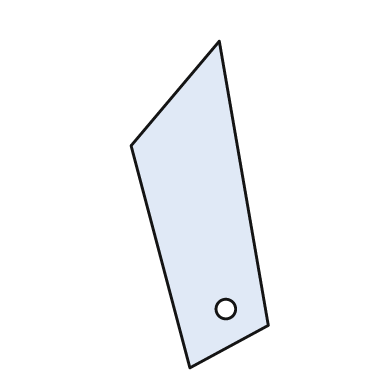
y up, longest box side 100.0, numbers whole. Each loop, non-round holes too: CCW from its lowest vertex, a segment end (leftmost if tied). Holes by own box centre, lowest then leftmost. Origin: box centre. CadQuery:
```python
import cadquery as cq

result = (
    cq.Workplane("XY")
    .moveTo(-3.0, -50.0)
    .lineTo(21.0, -37.0)
    .lineTo(6.0, 50.0)
    .lineTo(-21.0, 18.0)
    .close()
    .moveTo(8.0, -32.0)
    .circle(3.0)
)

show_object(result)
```